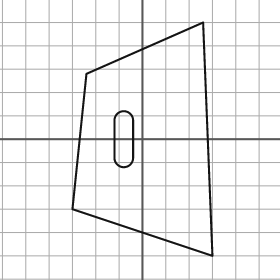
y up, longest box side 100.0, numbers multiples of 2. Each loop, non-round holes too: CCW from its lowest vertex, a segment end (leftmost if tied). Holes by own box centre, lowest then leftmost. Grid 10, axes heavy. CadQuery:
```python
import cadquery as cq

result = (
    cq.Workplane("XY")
    .moveTo(30.0, -50.0)
    .lineTo(26.0, 50.0)
    .lineTo(-24.0, 28.0)
    .lineTo(-30.0, -30.0)
    .close()
    .moveTo(-12.0, -8.0)
    .threePointArc((-8.0, -12.0), (-4.0, -8.0))
    .lineTo(-4.0, 8.0)
    .threePointArc((-8.0, 12.0), (-12.0, 8.0))
    .close()
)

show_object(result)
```